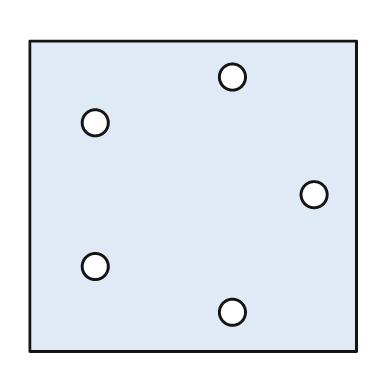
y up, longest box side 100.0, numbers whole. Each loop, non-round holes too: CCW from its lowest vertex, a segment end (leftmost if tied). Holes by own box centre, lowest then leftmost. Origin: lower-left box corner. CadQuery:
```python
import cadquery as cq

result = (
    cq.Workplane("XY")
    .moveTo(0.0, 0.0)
    .lineTo(100.0, 0.0)
    .lineTo(100.0, 95.0)
    .lineTo(0.0, 95.0)
    .close()
    .moveTo(62.0, 12.0)
    .circle(4.0)
    .moveTo(20.0, 26.0)
    .circle(4.0)
    .moveTo(87.0, 48.0)
    .circle(4.0)
    .moveTo(20.0, 70.0)
    .circle(4.0)
    .moveTo(62.0, 84.0)
    .circle(4.0)
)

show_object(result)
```